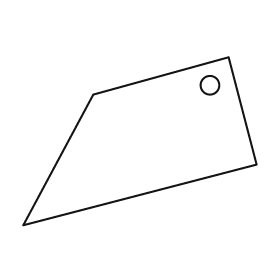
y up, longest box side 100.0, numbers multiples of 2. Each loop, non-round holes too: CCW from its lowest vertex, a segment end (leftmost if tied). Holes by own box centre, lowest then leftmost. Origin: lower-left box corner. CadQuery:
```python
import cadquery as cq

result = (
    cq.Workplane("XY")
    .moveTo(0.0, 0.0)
    .lineTo(100.0, 26.0)
    .lineTo(88.0, 72.0)
    .lineTo(30.0, 56.0)
    .close()
    .moveTo(80.0, 60.0)
    .circle(4.0)
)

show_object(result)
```